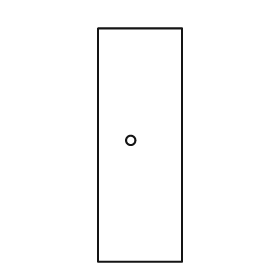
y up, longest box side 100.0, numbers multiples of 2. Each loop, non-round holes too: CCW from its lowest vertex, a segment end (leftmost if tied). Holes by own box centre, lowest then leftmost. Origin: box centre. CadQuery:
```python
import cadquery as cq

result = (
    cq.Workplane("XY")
    .moveTo(-18.0, -50.0)
    .lineTo(18.0, -50.0)
    .lineTo(18.0, 50.0)
    .lineTo(-18.0, 50.0)
    .close()
    .moveTo(-4.0, 2.0)
    .circle(2.0)
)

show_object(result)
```